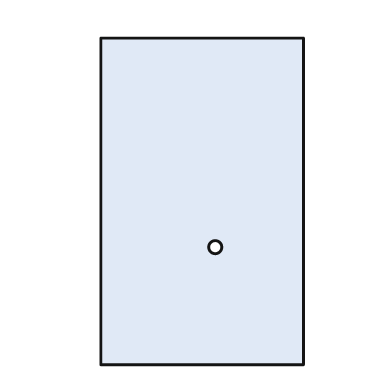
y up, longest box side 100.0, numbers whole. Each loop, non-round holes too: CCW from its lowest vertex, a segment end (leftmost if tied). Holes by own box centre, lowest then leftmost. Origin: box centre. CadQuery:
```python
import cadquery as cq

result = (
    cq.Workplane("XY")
    .moveTo(-31.0, -50.0)
    .lineTo(31.0, -50.0)
    .lineTo(31.0, 50.0)
    .lineTo(-31.0, 50.0)
    .close()
    .moveTo(4.0, -14.0)
    .circle(2.0)
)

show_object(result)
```